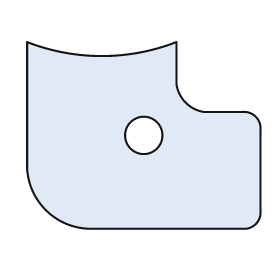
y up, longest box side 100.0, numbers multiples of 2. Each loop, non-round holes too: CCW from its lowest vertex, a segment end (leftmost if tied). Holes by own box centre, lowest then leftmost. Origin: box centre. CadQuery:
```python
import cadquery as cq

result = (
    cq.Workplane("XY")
    .moveTo(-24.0, -40.0)
    .lineTo(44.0, -40.0)
    .threePointArc((48.0, -38.0), (50.0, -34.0))
    .lineTo(50.0, 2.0)
    .threePointArc((48.0, 8.0), (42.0, 10.0))
    .lineTo(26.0, 10.0)
    .threePointArc((18.0, 14.0), (14.0, 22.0))
    .lineTo(14.0, 40.0)
    .threePointArc((-18.0, 34.0), (-50.0, 40.0))
    .lineTo(-50.0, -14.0)
    .threePointArc((-42.0, -32.0), (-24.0, -40.0))
    .close()
    .moveTo(0.0, 0.0)
    .circle(8.0)
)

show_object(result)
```